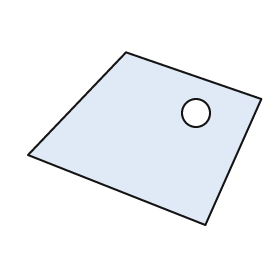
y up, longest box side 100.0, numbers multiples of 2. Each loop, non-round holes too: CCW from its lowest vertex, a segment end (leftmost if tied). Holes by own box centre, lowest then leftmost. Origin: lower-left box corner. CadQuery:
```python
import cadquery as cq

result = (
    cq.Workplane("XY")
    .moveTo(76.0, 0.0)
    .lineTo(100.0, 54.0)
    .lineTo(42.0, 74.0)
    .lineTo(0.0, 30.0)
    .close()
    .moveTo(72.0, 48.0)
    .circle(6.0)
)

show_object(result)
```